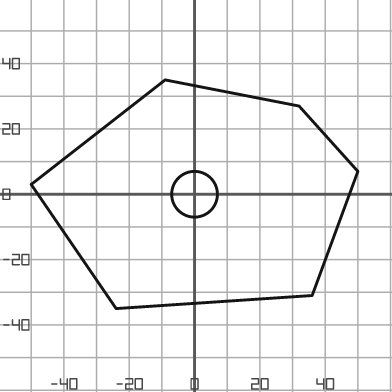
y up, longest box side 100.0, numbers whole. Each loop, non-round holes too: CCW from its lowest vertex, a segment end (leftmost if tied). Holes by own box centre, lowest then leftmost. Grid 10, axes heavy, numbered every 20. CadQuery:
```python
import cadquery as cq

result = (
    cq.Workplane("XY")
    .moveTo(-24.0, -35.0)
    .lineTo(36.0, -31.0)
    .lineTo(50.0, 7.0)
    .lineTo(32.0, 27.0)
    .lineTo(-9.0, 35.0)
    .lineTo(-50.0, 3.0)
    .close()
    .moveTo(0.0, 0.0)
    .circle(7.0)
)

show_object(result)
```